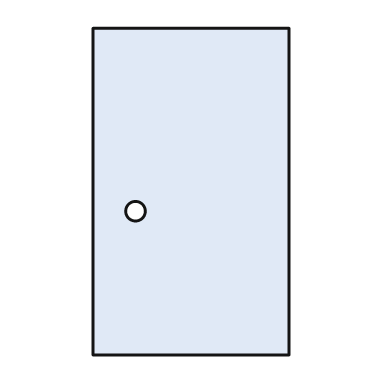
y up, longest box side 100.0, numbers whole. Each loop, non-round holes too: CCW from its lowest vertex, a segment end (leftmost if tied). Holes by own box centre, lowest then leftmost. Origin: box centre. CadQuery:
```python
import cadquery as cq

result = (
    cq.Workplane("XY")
    .moveTo(-30.0, -50.0)
    .lineTo(30.0, -50.0)
    .lineTo(30.0, 50.0)
    .lineTo(-30.0, 50.0)
    .close()
    .moveTo(-17.0, -6.0)
    .circle(3.0)
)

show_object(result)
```